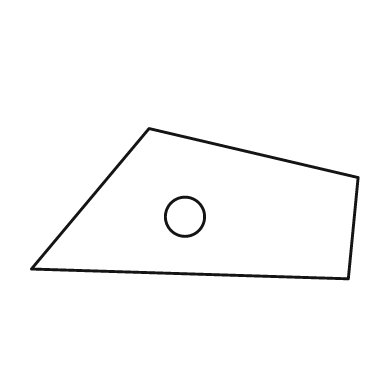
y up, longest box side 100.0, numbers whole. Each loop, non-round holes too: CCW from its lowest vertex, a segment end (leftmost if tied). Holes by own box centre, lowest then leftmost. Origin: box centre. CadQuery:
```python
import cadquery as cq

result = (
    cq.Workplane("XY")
    .moveTo(47.0, -23.0)
    .lineTo(50.0, 8.0)
    .lineTo(-14.0, 23.0)
    .lineTo(-50.0, -20.0)
    .close()
    .moveTo(-3.0, -4.0)
    .circle(6.0)
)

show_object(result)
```